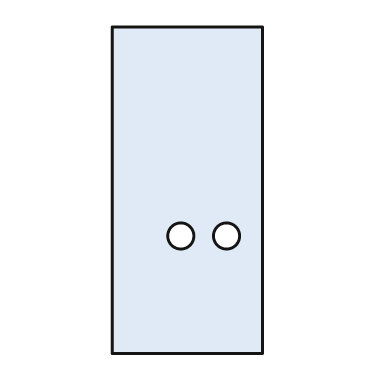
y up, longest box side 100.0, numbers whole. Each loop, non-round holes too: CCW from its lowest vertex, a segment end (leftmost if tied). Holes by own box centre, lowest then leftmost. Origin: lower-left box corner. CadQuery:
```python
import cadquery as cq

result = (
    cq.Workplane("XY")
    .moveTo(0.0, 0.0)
    .lineTo(46.0, 0.0)
    .lineTo(46.0, 100.0)
    .lineTo(0.0, 100.0)
    .close()
    .moveTo(21.0, 36.0)
    .circle(4.0)
    .moveTo(35.0, 36.0)
    .circle(4.0)
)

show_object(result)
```